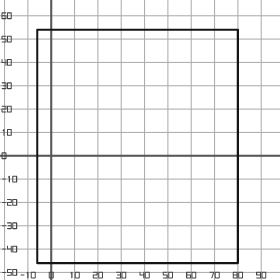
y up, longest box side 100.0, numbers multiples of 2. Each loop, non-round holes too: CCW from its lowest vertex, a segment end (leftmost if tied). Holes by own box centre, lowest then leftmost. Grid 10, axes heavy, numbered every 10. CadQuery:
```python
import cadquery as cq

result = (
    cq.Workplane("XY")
    .moveTo(-6.0, -46.0)
    .lineTo(80.0, -46.0)
    .lineTo(80.0, 54.0)
    .lineTo(-6.0, 54.0)
    .close()
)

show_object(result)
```